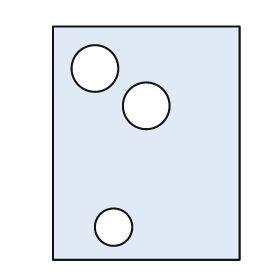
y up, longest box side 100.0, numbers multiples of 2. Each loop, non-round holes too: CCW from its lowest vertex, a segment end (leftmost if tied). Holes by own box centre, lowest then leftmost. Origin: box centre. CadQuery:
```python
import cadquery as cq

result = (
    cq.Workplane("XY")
    .moveTo(-40.0, -50.0)
    .lineTo(40.0, -50.0)
    .lineTo(40.0, 50.0)
    .lineTo(-40.0, 50.0)
    .close()
    .moveTo(-14.0, -36.0)
    .circle(8.0)
    .moveTo(0.0, 16.0)
    .circle(10.0)
    .moveTo(-22.0, 32.0)
    .circle(10.0)
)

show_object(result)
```